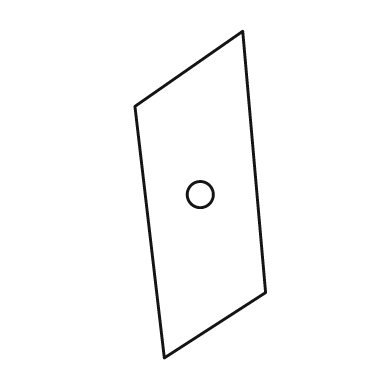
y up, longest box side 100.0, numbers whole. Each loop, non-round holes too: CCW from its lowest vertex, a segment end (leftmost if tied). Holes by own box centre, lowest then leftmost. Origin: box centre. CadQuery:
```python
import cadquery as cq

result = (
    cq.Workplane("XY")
    .moveTo(-11.0, -50.0)
    .lineTo(20.0, -30.0)
    .lineTo(13.0, 50.0)
    .lineTo(-20.0, 27.0)
    .close()
    .moveTo(0.0, 0.0)
    .circle(4.0)
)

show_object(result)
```